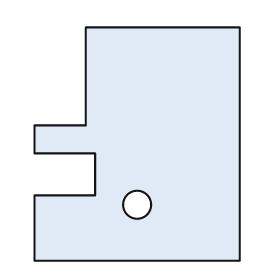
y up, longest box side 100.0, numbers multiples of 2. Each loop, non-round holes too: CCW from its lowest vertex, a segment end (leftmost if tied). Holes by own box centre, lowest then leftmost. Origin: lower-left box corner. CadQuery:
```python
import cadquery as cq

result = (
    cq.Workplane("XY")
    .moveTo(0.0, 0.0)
    .lineTo(88.0, 0.0)
    .lineTo(88.0, 100.0)
    .lineTo(22.0, 100.0)
    .lineTo(22.0, 58.0)
    .lineTo(0.0, 58.0)
    .lineTo(0.0, 46.0)
    .lineTo(26.0, 46.0)
    .lineTo(26.0, 28.0)
    .lineTo(0.0, 28.0)
    .close()
    .moveTo(44.0, 24.0)
    .circle(6.0)
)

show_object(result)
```